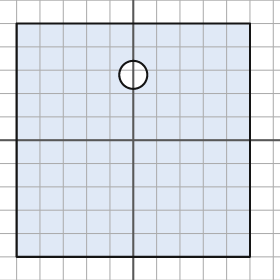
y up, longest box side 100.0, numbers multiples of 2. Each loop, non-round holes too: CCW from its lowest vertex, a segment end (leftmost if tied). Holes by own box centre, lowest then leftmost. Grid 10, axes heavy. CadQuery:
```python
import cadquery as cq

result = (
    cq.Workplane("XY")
    .moveTo(-50.0, -50.0)
    .lineTo(50.0, -50.0)
    .lineTo(50.0, 50.0)
    .lineTo(-50.0, 50.0)
    .close()
    .moveTo(0.0, 28.0)
    .circle(6.0)
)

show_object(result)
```